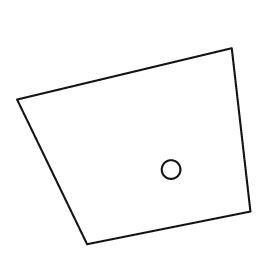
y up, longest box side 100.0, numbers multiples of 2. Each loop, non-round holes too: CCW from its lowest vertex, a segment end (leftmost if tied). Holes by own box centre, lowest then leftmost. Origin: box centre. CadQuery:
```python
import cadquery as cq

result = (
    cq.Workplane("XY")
    .moveTo(-20.0, -42.0)
    .lineTo(50.0, -28.0)
    .lineTo(42.0, 42.0)
    .lineTo(-50.0, 20.0)
    .close()
    .moveTo(16.0, -10.0)
    .circle(4.0)
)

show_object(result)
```